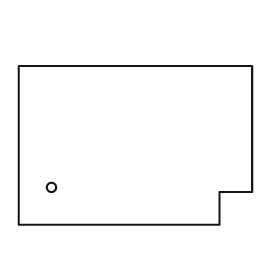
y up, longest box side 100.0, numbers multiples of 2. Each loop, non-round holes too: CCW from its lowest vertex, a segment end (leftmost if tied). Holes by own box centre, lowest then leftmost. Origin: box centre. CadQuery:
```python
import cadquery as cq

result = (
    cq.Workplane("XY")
    .moveTo(-50.0, -34.0)
    .lineTo(36.0, -34.0)
    .lineTo(36.0, -20.0)
    .lineTo(50.0, -20.0)
    .lineTo(50.0, 34.0)
    .lineTo(-50.0, 34.0)
    .close()
    .moveTo(-36.0, -18.0)
    .circle(2.0)
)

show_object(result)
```